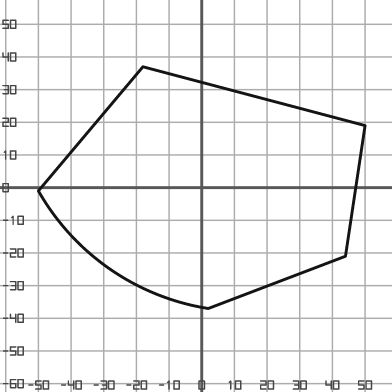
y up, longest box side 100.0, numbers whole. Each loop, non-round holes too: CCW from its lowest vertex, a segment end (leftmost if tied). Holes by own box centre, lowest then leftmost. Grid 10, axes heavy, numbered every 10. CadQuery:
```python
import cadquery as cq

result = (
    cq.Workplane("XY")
    .moveTo(2.0, -37.0)
    .lineTo(44.0, -21.0)
    .lineTo(50.0, 19.0)
    .lineTo(-18.0, 37.0)
    .lineTo(-50.0, -1.0)
    .threePointArc((-28.0, -25.0), (2.0, -37.0))
    .close()
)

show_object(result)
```